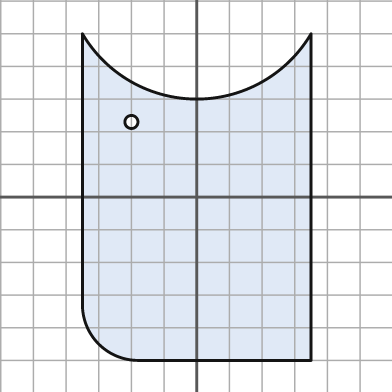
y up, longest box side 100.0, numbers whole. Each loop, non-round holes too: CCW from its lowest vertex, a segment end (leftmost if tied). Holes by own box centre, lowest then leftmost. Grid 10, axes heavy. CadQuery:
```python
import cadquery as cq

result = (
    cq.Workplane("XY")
    .moveTo(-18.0, -50.0)
    .lineTo(35.0, -50.0)
    .lineTo(35.0, 50.0)
    .threePointArc((0.0, 30.0), (-35.0, 50.0))
    .lineTo(-35.0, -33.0)
    .threePointArc((-30.0, -45.0), (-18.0, -50.0))
    .close()
    .moveTo(-20.0, 23.0)
    .circle(2.0)
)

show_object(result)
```